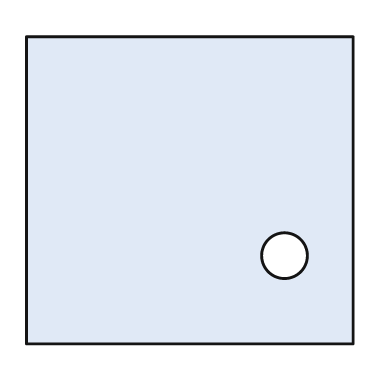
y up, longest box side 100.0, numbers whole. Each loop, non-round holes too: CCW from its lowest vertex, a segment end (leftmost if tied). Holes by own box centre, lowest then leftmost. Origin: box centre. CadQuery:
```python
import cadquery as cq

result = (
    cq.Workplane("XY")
    .moveTo(-50.0, -47.0)
    .lineTo(50.0, -47.0)
    .lineTo(50.0, 47.0)
    .lineTo(-50.0, 47.0)
    .close()
    .moveTo(29.0, -20.0)
    .circle(7.0)
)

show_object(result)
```